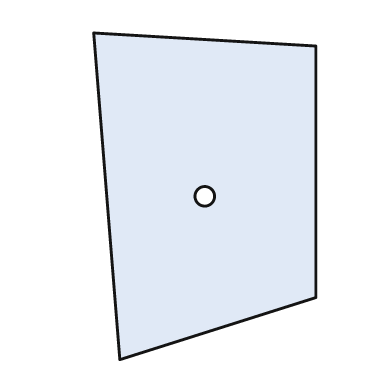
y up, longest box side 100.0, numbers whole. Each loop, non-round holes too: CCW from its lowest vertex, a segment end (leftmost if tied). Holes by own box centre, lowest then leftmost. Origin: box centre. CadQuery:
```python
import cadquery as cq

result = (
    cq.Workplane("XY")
    .moveTo(-26.0, -50.0)
    .lineTo(34.0, -31.0)
    .lineTo(34.0, 46.0)
    .lineTo(-34.0, 50.0)
    .close()
    .moveTo(0.0, 0.0)
    .circle(3.0)
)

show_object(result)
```